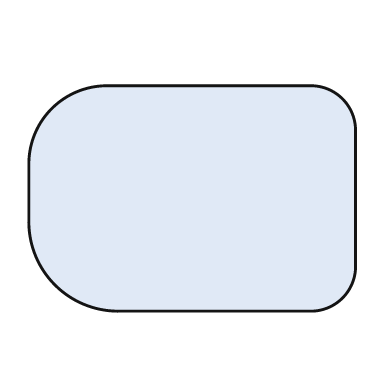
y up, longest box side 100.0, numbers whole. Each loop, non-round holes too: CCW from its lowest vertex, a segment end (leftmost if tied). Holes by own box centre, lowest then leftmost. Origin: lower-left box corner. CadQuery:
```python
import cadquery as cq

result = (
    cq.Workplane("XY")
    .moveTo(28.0, 0.0)
    .lineTo(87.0, 0.0)
    .threePointArc((96.0, 4.0), (100.0, 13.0))
    .lineTo(100.0, 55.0)
    .threePointArc((96.0, 65.0), (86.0, 69.0))
    .lineTo(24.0, 69.0)
    .threePointArc((7.0, 62.0), (0.0, 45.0))
    .lineTo(0.0, 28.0)
    .threePointArc((8.0, 8.0), (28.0, 0.0))
    .close()
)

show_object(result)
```